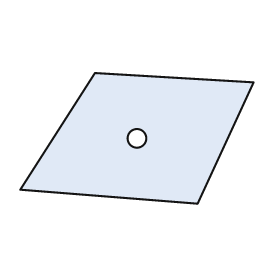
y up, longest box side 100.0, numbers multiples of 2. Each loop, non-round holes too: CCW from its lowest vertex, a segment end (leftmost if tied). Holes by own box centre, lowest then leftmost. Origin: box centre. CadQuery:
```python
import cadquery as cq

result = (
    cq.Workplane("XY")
    .moveTo(26.0, -28.0)
    .lineTo(50.0, 24.0)
    .lineTo(-18.0, 28.0)
    .lineTo(-50.0, -22.0)
    .close()
    .moveTo(0.0, 0.0)
    .circle(4.0)
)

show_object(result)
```